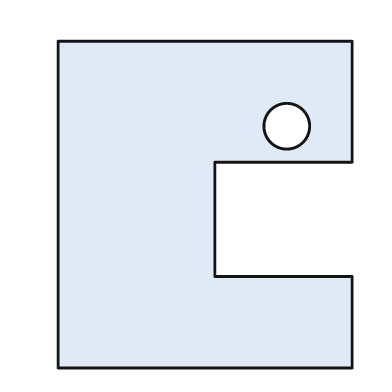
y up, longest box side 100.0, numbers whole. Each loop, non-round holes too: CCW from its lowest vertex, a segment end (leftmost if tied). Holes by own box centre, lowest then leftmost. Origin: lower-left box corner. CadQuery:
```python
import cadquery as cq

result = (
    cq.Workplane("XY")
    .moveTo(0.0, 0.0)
    .lineTo(90.0, 0.0)
    .lineTo(90.0, 28.0)
    .lineTo(48.0, 28.0)
    .lineTo(48.0, 63.0)
    .lineTo(90.0, 63.0)
    .lineTo(90.0, 100.0)
    .lineTo(0.0, 100.0)
    .close()
    .moveTo(70.0, 74.0)
    .circle(7.0)
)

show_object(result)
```